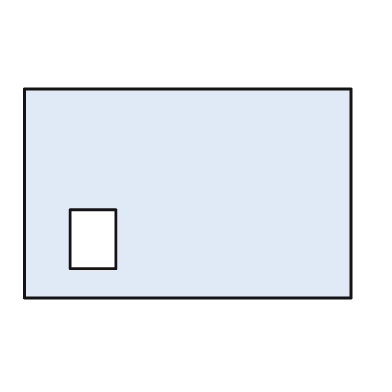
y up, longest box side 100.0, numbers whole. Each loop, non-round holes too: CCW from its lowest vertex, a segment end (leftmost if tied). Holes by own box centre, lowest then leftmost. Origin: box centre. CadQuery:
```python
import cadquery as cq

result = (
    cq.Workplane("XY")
    .moveTo(-50.0, -32.0)
    .lineTo(50.0, -32.0)
    .lineTo(50.0, 32.0)
    .lineTo(-50.0, 32.0)
    .close()
    .moveTo(-36.0, -23.0)
    .lineTo(-22.0, -23.0)
    .lineTo(-22.0, -5.0)
    .lineTo(-36.0, -5.0)
    .close()
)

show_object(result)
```